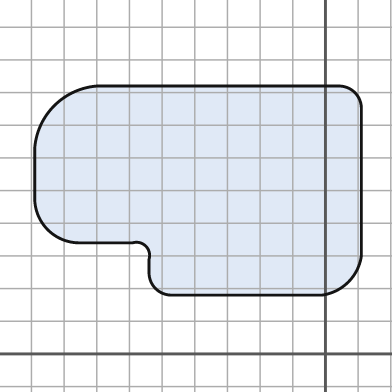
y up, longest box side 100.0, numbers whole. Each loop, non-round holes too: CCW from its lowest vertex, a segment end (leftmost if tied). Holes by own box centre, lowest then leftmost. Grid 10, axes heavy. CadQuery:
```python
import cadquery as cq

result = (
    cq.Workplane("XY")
    .moveTo(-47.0, 18.0)
    .lineTo(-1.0, 18.0)
    .threePointArc((7.0, 22.0), (11.0, 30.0))
    .lineTo(11.0, 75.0)
    .threePointArc((9.0, 80.0), (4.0, 82.0))
    .lineTo(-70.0, 82.0)
    .threePointArc((-83.0, 76.0), (-89.0, 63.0))
    .lineTo(-89.0, 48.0)
    .threePointArc((-85.0, 38.0), (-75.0, 34.0))
    .lineTo(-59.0, 34.0)
    .threePointArc((-55.0, 33.0), (-54.0, 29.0))
    .lineTo(-54.0, 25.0)
    .threePointArc((-52.0, 20.0), (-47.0, 18.0))
    .close()
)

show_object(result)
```